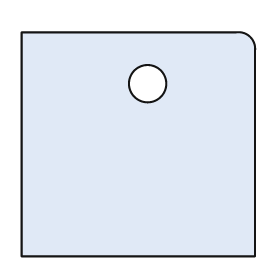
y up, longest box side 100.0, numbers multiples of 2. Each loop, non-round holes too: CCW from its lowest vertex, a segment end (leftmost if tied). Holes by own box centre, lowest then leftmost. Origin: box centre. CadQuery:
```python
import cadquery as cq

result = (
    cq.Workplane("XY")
    .moveTo(-50.0, -48.0)
    .lineTo(50.0, -48.0)
    .lineTo(50.0, 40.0)
    .threePointArc((48.0, 46.0), (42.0, 48.0))
    .lineTo(-50.0, 48.0)
    .close()
    .moveTo(4.0, 26.0)
    .circle(8.0)
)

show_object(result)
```